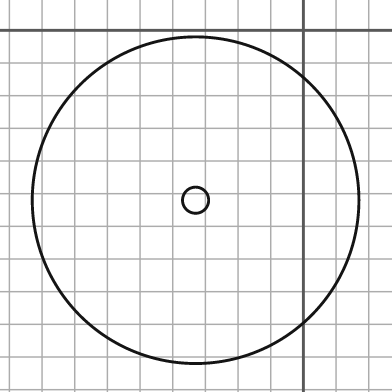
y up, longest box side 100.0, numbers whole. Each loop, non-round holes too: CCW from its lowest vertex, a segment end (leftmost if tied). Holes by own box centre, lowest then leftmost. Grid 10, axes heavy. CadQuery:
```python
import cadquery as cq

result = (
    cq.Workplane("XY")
    .moveTo(-33.0, -52.0)
    .circle(50.0)
    .moveTo(-33.0, -52.0)
    .circle(4.0)
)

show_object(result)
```